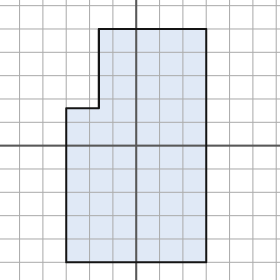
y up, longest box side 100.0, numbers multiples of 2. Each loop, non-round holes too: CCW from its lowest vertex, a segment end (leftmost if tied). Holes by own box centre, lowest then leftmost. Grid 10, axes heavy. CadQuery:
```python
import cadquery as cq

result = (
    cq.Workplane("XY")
    .moveTo(-30.0, -50.0)
    .lineTo(30.0, -50.0)
    .lineTo(30.0, 50.0)
    .lineTo(-16.0, 50.0)
    .lineTo(-16.0, 16.0)
    .lineTo(-30.0, 16.0)
    .close()
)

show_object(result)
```